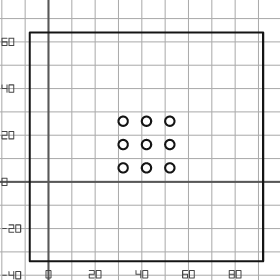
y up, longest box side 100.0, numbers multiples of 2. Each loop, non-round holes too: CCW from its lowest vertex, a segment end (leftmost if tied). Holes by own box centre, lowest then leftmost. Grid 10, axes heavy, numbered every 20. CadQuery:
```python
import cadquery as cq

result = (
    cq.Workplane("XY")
    .moveTo(-8.0, -34.0)
    .lineTo(92.0, -34.0)
    .lineTo(92.0, 64.0)
    .lineTo(-8.0, 64.0)
    .close()
    .moveTo(32.0, 6.0)
    .circle(2.0)
    .moveTo(42.0, 6.0)
    .circle(2.0)
    .moveTo(52.0, 6.0)
    .circle(2.0)
    .moveTo(32.0, 16.0)
    .circle(2.0)
    .moveTo(42.0, 16.0)
    .circle(2.0)
    .moveTo(52.0, 16.0)
    .circle(2.0)
    .moveTo(32.0, 26.0)
    .circle(2.0)
    .moveTo(42.0, 26.0)
    .circle(2.0)
    .moveTo(52.0, 26.0)
    .circle(2.0)
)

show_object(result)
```